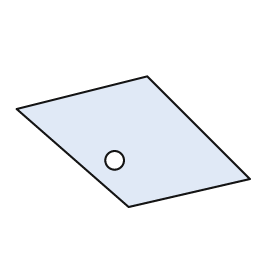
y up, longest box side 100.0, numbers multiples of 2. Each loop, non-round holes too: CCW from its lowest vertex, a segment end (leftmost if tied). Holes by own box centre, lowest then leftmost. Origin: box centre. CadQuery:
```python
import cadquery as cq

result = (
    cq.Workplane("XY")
    .moveTo(-2.0, -28.0)
    .lineTo(50.0, -16.0)
    .lineTo(6.0, 28.0)
    .lineTo(-50.0, 14.0)
    .close()
    .moveTo(-8.0, -8.0)
    .circle(4.0)
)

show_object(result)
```